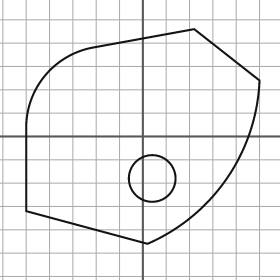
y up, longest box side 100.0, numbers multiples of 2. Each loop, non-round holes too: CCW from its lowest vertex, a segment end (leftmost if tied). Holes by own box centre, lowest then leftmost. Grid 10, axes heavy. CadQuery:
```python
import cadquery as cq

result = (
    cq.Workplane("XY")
    .moveTo(2.0, -46.0)
    .threePointArc((36.0, -18.0), (50.0, 24.0))
    .lineTo(22.0, 46.0)
    .lineTo(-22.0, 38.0)
    .threePointArc((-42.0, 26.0), (-50.0, 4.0))
    .lineTo(-50.0, -32.0)
    .close()
    .moveTo(4.0, -18.0)
    .circle(10.0)
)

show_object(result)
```